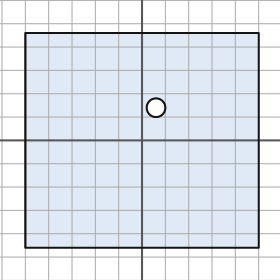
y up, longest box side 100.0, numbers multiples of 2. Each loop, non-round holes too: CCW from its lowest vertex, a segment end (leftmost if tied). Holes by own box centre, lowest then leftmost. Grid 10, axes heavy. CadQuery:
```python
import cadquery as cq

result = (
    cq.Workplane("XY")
    .moveTo(-50.0, -46.0)
    .lineTo(50.0, -46.0)
    .lineTo(50.0, 46.0)
    .lineTo(-50.0, 46.0)
    .close()
    .moveTo(6.0, 14.0)
    .circle(4.0)
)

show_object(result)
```